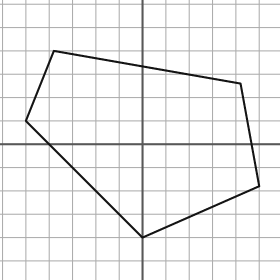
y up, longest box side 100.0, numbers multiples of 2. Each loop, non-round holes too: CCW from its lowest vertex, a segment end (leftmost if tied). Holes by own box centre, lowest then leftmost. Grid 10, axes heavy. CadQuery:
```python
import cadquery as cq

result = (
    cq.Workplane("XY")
    .moveTo(0.0, -40.0)
    .lineTo(50.0, -18.0)
    .lineTo(42.0, 26.0)
    .lineTo(-38.0, 40.0)
    .lineTo(-50.0, 10.0)
    .close()
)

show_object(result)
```